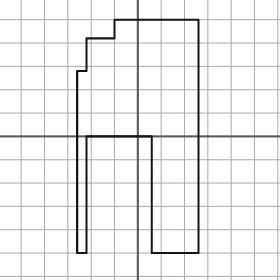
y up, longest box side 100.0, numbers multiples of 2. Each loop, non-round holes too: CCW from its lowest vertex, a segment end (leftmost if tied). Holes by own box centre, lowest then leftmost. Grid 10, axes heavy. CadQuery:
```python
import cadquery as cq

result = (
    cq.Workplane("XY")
    .moveTo(-26.0, -50.0)
    .lineTo(-22.0, -50.0)
    .lineTo(-22.0, 0.0)
    .lineTo(6.0, 0.0)
    .lineTo(6.0, -50.0)
    .lineTo(26.0, -50.0)
    .lineTo(26.0, 50.0)
    .lineTo(-10.0, 50.0)
    .lineTo(-10.0, 42.0)
    .lineTo(-22.0, 42.0)
    .lineTo(-22.0, 28.0)
    .lineTo(-26.0, 28.0)
    .close()
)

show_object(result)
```